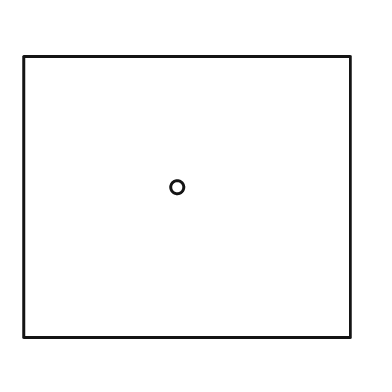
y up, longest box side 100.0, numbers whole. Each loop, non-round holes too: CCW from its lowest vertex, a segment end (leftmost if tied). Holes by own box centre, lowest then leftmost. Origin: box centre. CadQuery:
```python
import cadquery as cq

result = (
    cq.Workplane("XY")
    .moveTo(-50.0, -43.0)
    .lineTo(50.0, -43.0)
    .lineTo(50.0, 43.0)
    .lineTo(-50.0, 43.0)
    .close()
    .moveTo(-3.0, 3.0)
    .circle(2.0)
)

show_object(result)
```